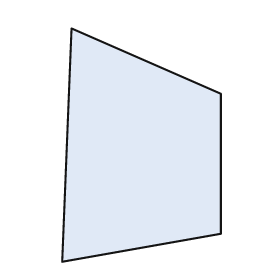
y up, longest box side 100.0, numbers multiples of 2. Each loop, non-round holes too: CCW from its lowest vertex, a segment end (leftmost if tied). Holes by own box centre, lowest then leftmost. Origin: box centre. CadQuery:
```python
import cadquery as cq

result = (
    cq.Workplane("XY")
    .moveTo(-34.0, -50.0)
    .lineTo(34.0, -38.0)
    .lineTo(34.0, 22.0)
    .lineTo(-30.0, 50.0)
    .close()
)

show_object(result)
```